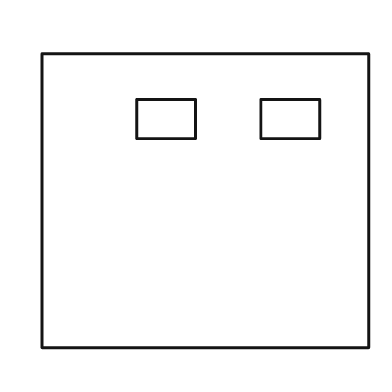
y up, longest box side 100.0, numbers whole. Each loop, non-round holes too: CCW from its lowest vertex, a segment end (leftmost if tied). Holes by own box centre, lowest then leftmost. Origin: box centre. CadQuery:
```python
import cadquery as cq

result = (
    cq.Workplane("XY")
    .moveTo(-50.0, -45.0)
    .lineTo(50.0, -45.0)
    .lineTo(50.0, 45.0)
    .lineTo(-50.0, 45.0)
    .close()
    .moveTo(-21.0, 19.0)
    .lineTo(-3.0, 19.0)
    .lineTo(-3.0, 31.0)
    .lineTo(-21.0, 31.0)
    .close()
    .moveTo(17.0, 19.0)
    .lineTo(35.0, 19.0)
    .lineTo(35.0, 31.0)
    .lineTo(17.0, 31.0)
    .close()
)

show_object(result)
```